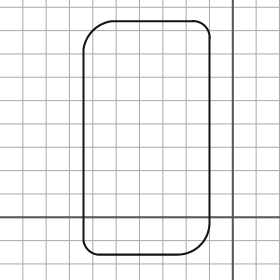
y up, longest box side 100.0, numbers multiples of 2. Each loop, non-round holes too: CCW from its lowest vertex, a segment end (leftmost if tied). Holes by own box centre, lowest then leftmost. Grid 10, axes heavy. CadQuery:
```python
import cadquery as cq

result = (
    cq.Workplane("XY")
    .moveTo(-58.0, -16.0)
    .lineTo(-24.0, -16.0)
    .threePointArc((-14.0, -12.0), (-10.0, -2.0))
    .lineTo(-10.0, 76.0)
    .threePointArc((-12.0, 82.0), (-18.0, 84.0))
    .lineTo(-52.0, 84.0)
    .threePointArc((-60.0, 80.0), (-64.0, 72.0))
    .lineTo(-64.0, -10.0)
    .threePointArc((-62.0, -14.0), (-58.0, -16.0))
    .close()
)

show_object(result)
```